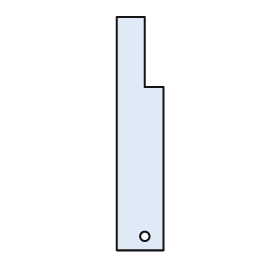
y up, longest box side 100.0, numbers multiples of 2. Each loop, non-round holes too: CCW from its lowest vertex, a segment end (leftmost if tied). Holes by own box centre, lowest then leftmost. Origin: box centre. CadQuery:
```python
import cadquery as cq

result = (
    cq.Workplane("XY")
    .moveTo(-10.0, -50.0)
    .lineTo(10.0, -50.0)
    .lineTo(10.0, 20.0)
    .lineTo(2.0, 20.0)
    .lineTo(2.0, 50.0)
    .lineTo(-10.0, 50.0)
    .close()
    .moveTo(2.0, -44.0)
    .circle(2.0)
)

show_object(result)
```